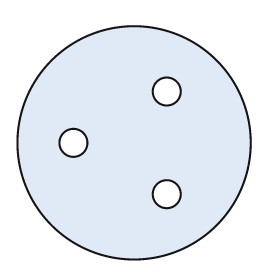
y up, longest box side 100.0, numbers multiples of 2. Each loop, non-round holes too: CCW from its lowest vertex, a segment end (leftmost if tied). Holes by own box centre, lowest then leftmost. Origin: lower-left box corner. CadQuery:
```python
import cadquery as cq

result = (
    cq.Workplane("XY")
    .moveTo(50.0, 50.0)
    .circle(50.0)
    .moveTo(64.0, 28.0)
    .circle(6.0)
    .moveTo(24.0, 50.0)
    .circle(6.0)
    .moveTo(64.0, 72.0)
    .circle(6.0)
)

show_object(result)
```